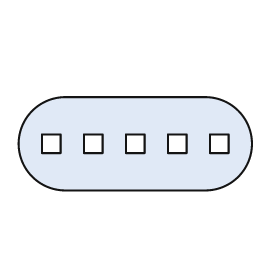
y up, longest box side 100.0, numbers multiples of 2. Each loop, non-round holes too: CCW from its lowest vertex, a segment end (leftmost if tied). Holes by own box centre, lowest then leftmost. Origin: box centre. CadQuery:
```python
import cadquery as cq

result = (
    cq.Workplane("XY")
    .moveTo(-30.0, -20.0)
    .lineTo(30.0, -20.0)
    .threePointArc((50.0, 0.0), (30.0, 20.0))
    .lineTo(-30.0, 20.0)
    .threePointArc((-50.0, 0.0), (-30.0, -20.0))
    .close()
    .moveTo(-40.0, -4.0)
    .lineTo(-32.0, -4.0)
    .lineTo(-32.0, 4.0)
    .lineTo(-40.0, 4.0)
    .close()
    .moveTo(-22.0, -4.0)
    .lineTo(-14.0, -4.0)
    .lineTo(-14.0, 4.0)
    .lineTo(-22.0, 4.0)
    .close()
    .moveTo(-4.0, -4.0)
    .lineTo(4.0, -4.0)
    .lineTo(4.0, 4.0)
    .lineTo(-4.0, 4.0)
    .close()
    .moveTo(14.0, -4.0)
    .lineTo(22.0, -4.0)
    .lineTo(22.0, 4.0)
    .lineTo(14.0, 4.0)
    .close()
    .moveTo(32.0, -4.0)
    .lineTo(40.0, -4.0)
    .lineTo(40.0, 4.0)
    .lineTo(32.0, 4.0)
    .close()
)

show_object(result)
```